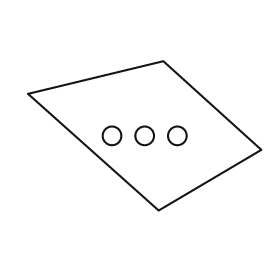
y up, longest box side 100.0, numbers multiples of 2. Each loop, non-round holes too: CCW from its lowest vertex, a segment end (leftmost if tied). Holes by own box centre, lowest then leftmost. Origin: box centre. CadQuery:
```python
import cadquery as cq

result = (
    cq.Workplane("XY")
    .moveTo(6.0, -32.0)
    .lineTo(50.0, -6.0)
    .lineTo(8.0, 32.0)
    .lineTo(-50.0, 18.0)
    .close()
    .moveTo(-14.0, 0.0)
    .circle(4.0)
    .moveTo(0.0, 0.0)
    .circle(4.0)
    .moveTo(14.0, 0.0)
    .circle(4.0)
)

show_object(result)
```